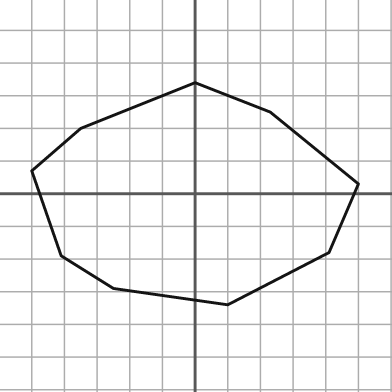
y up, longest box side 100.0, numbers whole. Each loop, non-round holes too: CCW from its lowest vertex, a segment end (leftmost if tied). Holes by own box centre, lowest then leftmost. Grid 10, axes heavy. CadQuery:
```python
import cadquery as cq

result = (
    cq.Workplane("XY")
    .moveTo(10.0, -34.0)
    .lineTo(41.0, -18.0)
    .lineTo(50.0, 3.0)
    .lineTo(23.0, 25.0)
    .lineTo(0.0, 34.0)
    .lineTo(-35.0, 20.0)
    .lineTo(-50.0, 7.0)
    .lineTo(-41.0, -19.0)
    .lineTo(-25.0, -29.0)
    .close()
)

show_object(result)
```